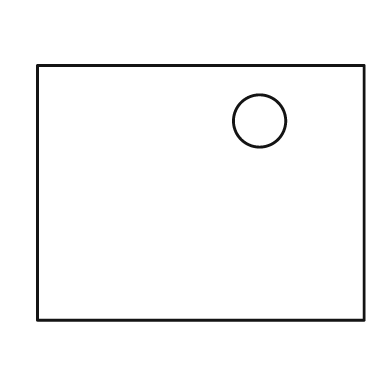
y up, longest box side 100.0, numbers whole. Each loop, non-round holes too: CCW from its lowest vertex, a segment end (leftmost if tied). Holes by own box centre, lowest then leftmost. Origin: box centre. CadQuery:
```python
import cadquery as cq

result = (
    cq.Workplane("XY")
    .moveTo(-50.0, -39.0)
    .lineTo(50.0, -39.0)
    .lineTo(50.0, 39.0)
    .lineTo(-50.0, 39.0)
    .close()
    .moveTo(18.0, 22.0)
    .circle(8.0)
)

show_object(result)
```